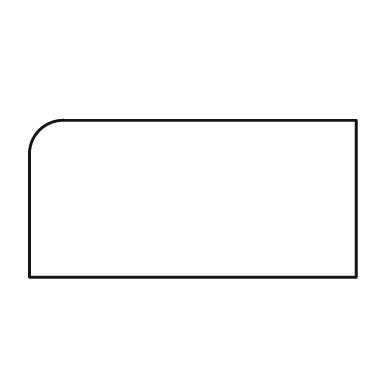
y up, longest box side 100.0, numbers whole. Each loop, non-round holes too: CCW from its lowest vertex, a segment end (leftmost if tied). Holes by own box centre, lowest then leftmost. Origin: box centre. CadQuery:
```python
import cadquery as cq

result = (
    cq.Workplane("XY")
    .moveTo(-50.0, -24.0)
    .lineTo(50.0, -24.0)
    .lineTo(50.0, 24.0)
    .lineTo(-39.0, 24.0)
    .threePointArc((-47.0, 21.0), (-50.0, 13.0))
    .close()
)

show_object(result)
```